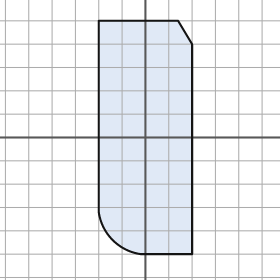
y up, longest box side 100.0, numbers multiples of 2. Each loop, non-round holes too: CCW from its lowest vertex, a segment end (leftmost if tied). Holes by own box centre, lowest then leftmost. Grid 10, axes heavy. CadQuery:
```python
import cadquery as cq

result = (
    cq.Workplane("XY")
    .moveTo(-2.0, -50.0)
    .lineTo(20.0, -50.0)
    .lineTo(20.0, 40.0)
    .lineTo(14.0, 50.0)
    .lineTo(-20.0, 50.0)
    .lineTo(-20.0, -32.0)
    .threePointArc((-14.0, -44.0), (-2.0, -50.0))
    .close()
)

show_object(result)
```